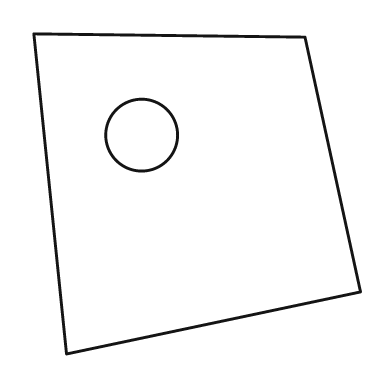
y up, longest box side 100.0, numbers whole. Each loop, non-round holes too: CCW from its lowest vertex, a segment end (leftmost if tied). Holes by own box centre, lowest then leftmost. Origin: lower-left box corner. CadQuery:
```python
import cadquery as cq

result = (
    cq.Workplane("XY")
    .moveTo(10.0, 0.0)
    .lineTo(100.0, 19.0)
    .lineTo(83.0, 97.0)
    .lineTo(0.0, 98.0)
    .close()
    .moveTo(33.0, 67.0)
    .circle(11.0)
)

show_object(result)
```